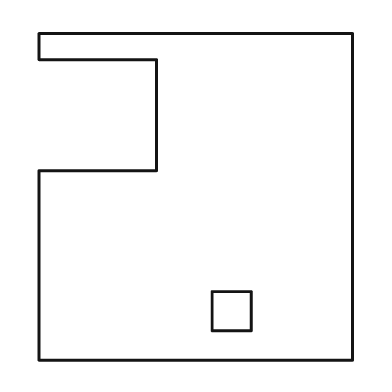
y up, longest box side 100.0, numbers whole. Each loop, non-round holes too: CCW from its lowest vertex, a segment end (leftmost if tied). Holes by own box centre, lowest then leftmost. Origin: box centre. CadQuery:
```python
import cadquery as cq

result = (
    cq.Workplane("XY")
    .moveTo(-48.0, -50.0)
    .lineTo(48.0, -50.0)
    .lineTo(48.0, 50.0)
    .lineTo(-48.0, 50.0)
    .lineTo(-48.0, 42.0)
    .lineTo(-12.0, 42.0)
    .lineTo(-12.0, 8.0)
    .lineTo(-48.0, 8.0)
    .close()
    .moveTo(5.0, -41.0)
    .lineTo(17.0, -41.0)
    .lineTo(17.0, -29.0)
    .lineTo(5.0, -29.0)
    .close()
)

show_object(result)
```